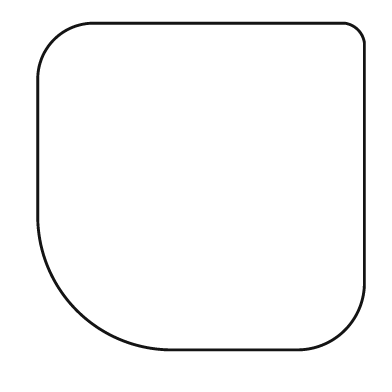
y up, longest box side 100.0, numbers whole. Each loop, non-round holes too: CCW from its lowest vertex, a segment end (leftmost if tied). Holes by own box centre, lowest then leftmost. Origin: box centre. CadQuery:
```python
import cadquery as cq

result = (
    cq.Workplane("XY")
    .moveTo(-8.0, -50.0)
    .lineTo(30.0, -50.0)
    .threePointArc((44.0, -44.0), (50.0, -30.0))
    .lineTo(50.0, 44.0)
    .threePointArc((48.0, 48.0), (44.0, 50.0))
    .lineTo(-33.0, 50.0)
    .threePointArc((-45.0, 45.0), (-50.0, 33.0))
    .lineTo(-50.0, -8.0)
    .threePointArc((-38.0, -38.0), (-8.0, -50.0))
    .close()
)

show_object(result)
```